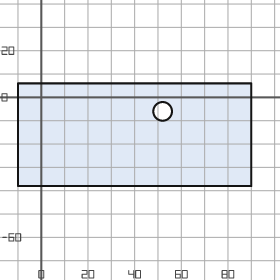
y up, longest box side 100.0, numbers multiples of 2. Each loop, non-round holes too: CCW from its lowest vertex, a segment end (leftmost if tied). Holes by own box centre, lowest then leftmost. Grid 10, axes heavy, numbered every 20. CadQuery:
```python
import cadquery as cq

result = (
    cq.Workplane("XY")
    .moveTo(-10.0, -38.0)
    .lineTo(90.0, -38.0)
    .lineTo(90.0, 6.0)
    .lineTo(-10.0, 6.0)
    .close()
    .moveTo(52.0, -6.0)
    .circle(4.0)
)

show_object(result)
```